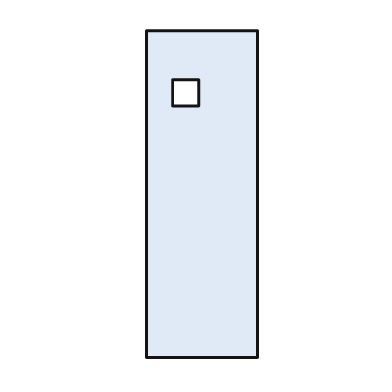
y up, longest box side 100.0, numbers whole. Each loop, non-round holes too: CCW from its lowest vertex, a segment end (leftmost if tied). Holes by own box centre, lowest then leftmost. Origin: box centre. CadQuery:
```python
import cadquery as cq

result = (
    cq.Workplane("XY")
    .moveTo(-17.0, -50.0)
    .lineTo(17.0, -50.0)
    .lineTo(17.0, 50.0)
    .lineTo(-17.0, 50.0)
    .close()
    .moveTo(-9.0, 27.0)
    .lineTo(-1.0, 27.0)
    .lineTo(-1.0, 35.0)
    .lineTo(-9.0, 35.0)
    .close()
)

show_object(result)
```